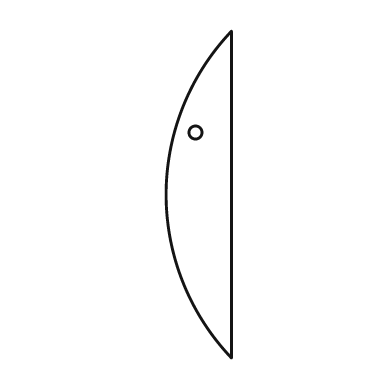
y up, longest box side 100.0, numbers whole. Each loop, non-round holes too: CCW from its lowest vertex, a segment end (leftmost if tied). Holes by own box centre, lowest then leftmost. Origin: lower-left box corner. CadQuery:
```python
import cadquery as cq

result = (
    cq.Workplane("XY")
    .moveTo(20.0, 0.0)
    .lineTo(20.0, 100.0)
    .threePointArc((0.0, 50.0), (20.0, 0.0))
    .close()
    .moveTo(9.0, 69.0)
    .circle(2.0)
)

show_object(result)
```